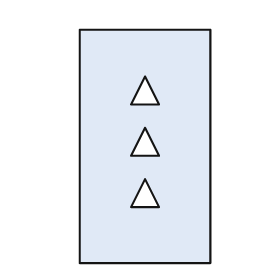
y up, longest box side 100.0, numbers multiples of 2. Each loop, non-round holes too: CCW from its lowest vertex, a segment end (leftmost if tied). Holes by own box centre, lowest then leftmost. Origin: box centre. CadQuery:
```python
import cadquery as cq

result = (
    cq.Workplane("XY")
    .moveTo(-28.0, -50.0)
    .lineTo(28.0, -50.0)
    .lineTo(28.0, 50.0)
    .lineTo(-28.0, 50.0)
    .close()
    .moveTo(-6.0, -26.0)
    .lineTo(6.0, -26.0)
    .lineTo(0.0, -14.0)
    .close()
    .moveTo(-6.0, -4.0)
    .lineTo(6.0, -4.0)
    .lineTo(0.0, 8.0)
    .close()
    .moveTo(-6.0, 18.0)
    .lineTo(6.0, 18.0)
    .lineTo(0.0, 30.0)
    .close()
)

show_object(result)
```